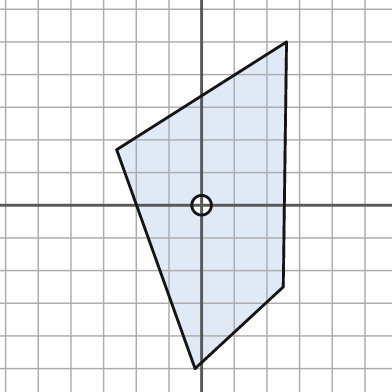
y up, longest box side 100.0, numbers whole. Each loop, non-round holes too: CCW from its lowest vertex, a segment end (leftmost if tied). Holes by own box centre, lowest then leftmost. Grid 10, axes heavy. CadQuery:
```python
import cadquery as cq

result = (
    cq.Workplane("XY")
    .moveTo(-2.0, -50.0)
    .lineTo(25.0, -25.0)
    .lineTo(26.0, 50.0)
    .lineTo(-26.0, 17.0)
    .close()
    .moveTo(0.0, 0.0)
    .circle(3.0)
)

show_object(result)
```